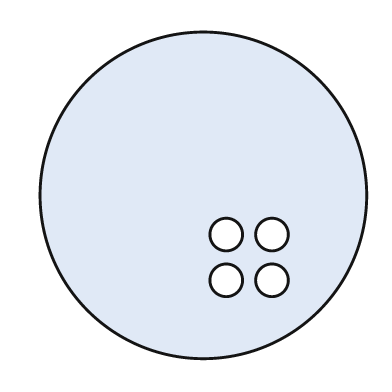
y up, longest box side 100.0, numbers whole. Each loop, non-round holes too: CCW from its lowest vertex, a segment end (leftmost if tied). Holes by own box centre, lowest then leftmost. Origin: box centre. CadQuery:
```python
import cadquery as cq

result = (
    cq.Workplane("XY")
    .moveTo(0.0, 0.0)
    .circle(50.0)
    .moveTo(7.0, -26.0)
    .circle(5.0)
    .moveTo(21.0, -26.0)
    .circle(5.0)
    .moveTo(7.0, -12.0)
    .circle(5.0)
    .moveTo(21.0, -12.0)
    .circle(5.0)
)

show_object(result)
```